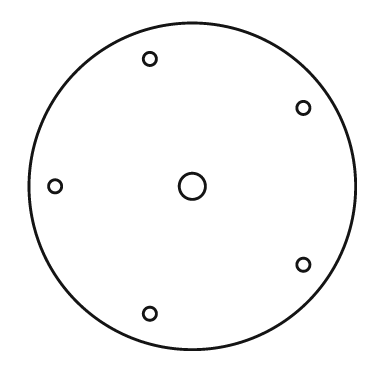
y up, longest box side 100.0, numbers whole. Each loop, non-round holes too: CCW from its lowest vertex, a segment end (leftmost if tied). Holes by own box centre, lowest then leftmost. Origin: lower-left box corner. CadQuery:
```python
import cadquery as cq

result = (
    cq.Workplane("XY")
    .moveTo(50.0, 50.0)
    .circle(50.0)
    .moveTo(37.0, 11.0)
    .circle(2.0)
    .moveTo(84.0, 26.0)
    .circle(2.0)
    .moveTo(8.0, 50.0)
    .circle(2.0)
    .moveTo(50.0, 50.0)
    .circle(4.0)
    .moveTo(84.0, 74.0)
    .circle(2.0)
    .moveTo(37.0, 89.0)
    .circle(2.0)
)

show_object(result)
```